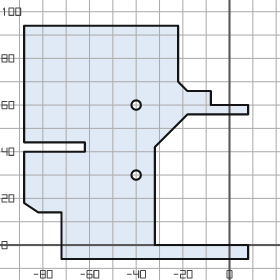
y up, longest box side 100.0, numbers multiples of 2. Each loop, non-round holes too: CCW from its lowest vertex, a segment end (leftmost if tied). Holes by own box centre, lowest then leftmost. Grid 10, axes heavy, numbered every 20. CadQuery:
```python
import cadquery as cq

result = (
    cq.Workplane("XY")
    .moveTo(-72.0, -6.0)
    .lineTo(8.0, -6.0)
    .lineTo(8.0, 0.0)
    .lineTo(-32.0, 0.0)
    .lineTo(-32.0, 42.0)
    .lineTo(-18.0, 56.0)
    .lineTo(8.0, 56.0)
    .lineTo(8.0, 60.0)
    .lineTo(-8.0, 60.0)
    .lineTo(-8.0, 66.0)
    .lineTo(-18.0, 66.0)
    .lineTo(-22.0, 70.0)
    .lineTo(-22.0, 94.0)
    .lineTo(-88.0, 94.0)
    .lineTo(-88.0, 44.0)
    .lineTo(-62.0, 44.0)
    .lineTo(-62.0, 40.0)
    .lineTo(-88.0, 40.0)
    .lineTo(-88.0, 18.0)
    .lineTo(-82.0, 14.0)
    .lineTo(-72.0, 14.0)
    .close()
    .moveTo(-40.0, 30.0)
    .circle(2.0)
    .moveTo(-40.0, 60.0)
    .circle(2.0)
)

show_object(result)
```